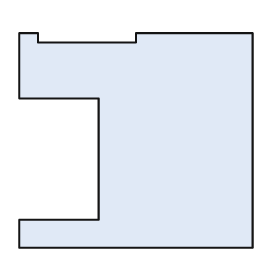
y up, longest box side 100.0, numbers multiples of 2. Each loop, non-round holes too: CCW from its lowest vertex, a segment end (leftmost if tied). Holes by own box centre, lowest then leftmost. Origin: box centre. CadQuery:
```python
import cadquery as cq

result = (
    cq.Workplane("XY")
    .moveTo(-50.0, -46.0)
    .lineTo(50.0, -46.0)
    .lineTo(50.0, 46.0)
    .lineTo(0.0, 46.0)
    .lineTo(0.0, 42.0)
    .lineTo(-42.0, 42.0)
    .lineTo(-42.0, 46.0)
    .lineTo(-50.0, 46.0)
    .lineTo(-50.0, 18.0)
    .lineTo(-16.0, 18.0)
    .lineTo(-16.0, -34.0)
    .lineTo(-50.0, -34.0)
    .close()
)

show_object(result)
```